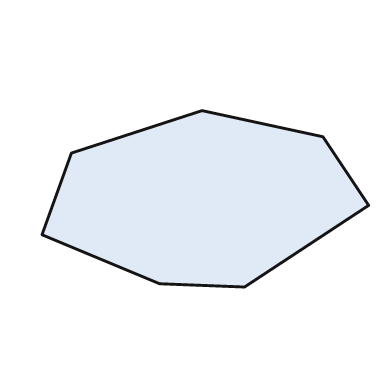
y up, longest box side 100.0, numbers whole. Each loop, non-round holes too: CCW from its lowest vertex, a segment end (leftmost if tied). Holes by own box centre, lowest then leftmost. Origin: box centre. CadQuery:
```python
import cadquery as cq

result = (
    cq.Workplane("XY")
    .moveTo(12.0, -27.0)
    .lineTo(50.0, -2.0)
    .lineTo(36.0, 19.0)
    .lineTo(-1.0, 27.0)
    .lineTo(-41.0, 14.0)
    .lineTo(-50.0, -11.0)
    .lineTo(-14.0, -26.0)
    .close()
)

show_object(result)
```